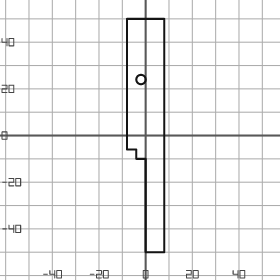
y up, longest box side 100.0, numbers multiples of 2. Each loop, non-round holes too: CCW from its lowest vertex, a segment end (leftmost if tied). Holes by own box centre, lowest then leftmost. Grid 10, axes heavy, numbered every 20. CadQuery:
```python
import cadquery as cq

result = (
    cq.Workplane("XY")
    .moveTo(0.0, -50.0)
    .lineTo(8.0, -50.0)
    .lineTo(8.0, 50.0)
    .lineTo(-8.0, 50.0)
    .lineTo(-8.0, -6.0)
    .lineTo(-4.0, -6.0)
    .lineTo(-4.0, -10.0)
    .lineTo(0.0, -10.0)
    .close()
    .moveTo(-2.0, 24.0)
    .circle(2.0)
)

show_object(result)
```